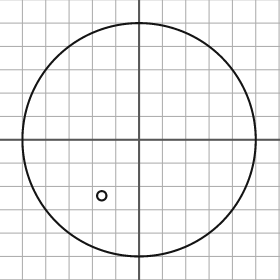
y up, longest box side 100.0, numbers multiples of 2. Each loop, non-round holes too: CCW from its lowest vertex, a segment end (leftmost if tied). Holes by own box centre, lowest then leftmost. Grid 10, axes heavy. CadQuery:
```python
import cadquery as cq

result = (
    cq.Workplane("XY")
    .moveTo(0.0, 0.0)
    .circle(50.0)
    .moveTo(-16.0, -24.0)
    .circle(2.0)
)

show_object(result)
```